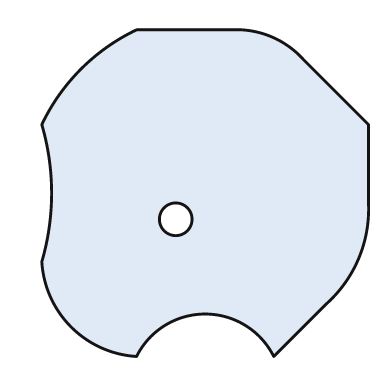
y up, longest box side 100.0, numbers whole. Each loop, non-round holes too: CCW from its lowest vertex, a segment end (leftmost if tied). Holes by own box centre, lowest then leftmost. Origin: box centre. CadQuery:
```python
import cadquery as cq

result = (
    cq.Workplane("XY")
    .moveTo(-21.0, -50.0)
    .threePointArc((0.0, -37.0), (21.0, -50.0))
    .lineTo(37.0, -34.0)
    .threePointArc((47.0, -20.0), (50.0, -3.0))
    .lineTo(50.0, 21.0)
    .lineTo(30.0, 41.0)
    .threePointArc((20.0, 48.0), (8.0, 50.0))
    .lineTo(-21.0, 50.0)
    .threePointArc((-38.0, 38.0), (-50.0, 21.0))
    .threePointArc((-47.0, 0.0), (-50.0, -21.0))
    .threePointArc((-41.0, -41.0), (-21.0, -50.0))
    .close()
    .moveTo(-9.0, -8.0)
    .circle(5.0)
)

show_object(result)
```